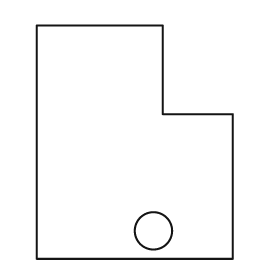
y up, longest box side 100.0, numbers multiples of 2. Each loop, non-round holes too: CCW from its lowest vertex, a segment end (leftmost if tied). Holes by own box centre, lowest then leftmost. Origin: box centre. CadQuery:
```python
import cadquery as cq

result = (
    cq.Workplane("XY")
    .moveTo(-42.0, -50.0)
    .lineTo(42.0, -50.0)
    .lineTo(42.0, 12.0)
    .lineTo(12.0, 12.0)
    .lineTo(12.0, 50.0)
    .lineTo(-42.0, 50.0)
    .close()
    .moveTo(8.0, -38.0)
    .circle(8.0)
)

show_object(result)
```